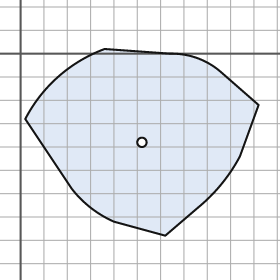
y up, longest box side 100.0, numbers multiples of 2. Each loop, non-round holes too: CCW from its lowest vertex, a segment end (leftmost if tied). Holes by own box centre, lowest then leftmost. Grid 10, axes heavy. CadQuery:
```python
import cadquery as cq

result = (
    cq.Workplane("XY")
    .moveTo(62.0, -78.0)
    .lineTo(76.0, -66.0)
    .threePointArc((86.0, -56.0), (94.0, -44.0))
    .lineTo(102.0, -22.0)
    .lineTo(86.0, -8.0)
    .threePointArc((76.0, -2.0), (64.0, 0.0))
    .lineTo(36.0, 2.0)
    .threePointArc((16.0, -10.0), (2.0, -28.0))
    .lineTo(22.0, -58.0)
    .threePointArc((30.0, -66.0), (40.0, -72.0))
    .close()
    .moveTo(52.0, -38.0)
    .circle(2.0)
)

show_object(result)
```